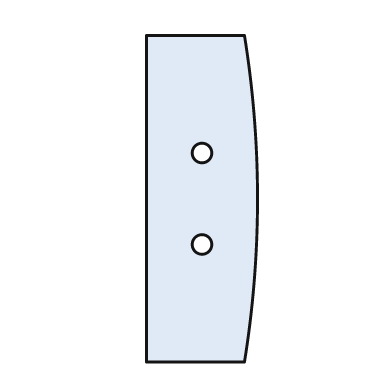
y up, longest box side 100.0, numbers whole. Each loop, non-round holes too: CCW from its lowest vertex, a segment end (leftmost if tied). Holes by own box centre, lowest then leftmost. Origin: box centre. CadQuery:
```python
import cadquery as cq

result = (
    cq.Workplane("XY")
    .moveTo(-17.0, -50.0)
    .lineTo(13.0, -50.0)
    .threePointArc((17.0, 0.0), (13.0, 50.0))
    .lineTo(-17.0, 50.0)
    .close()
    .moveTo(0.0, -14.0)
    .circle(3.0)
    .moveTo(0.0, 14.0)
    .circle(3.0)
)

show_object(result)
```